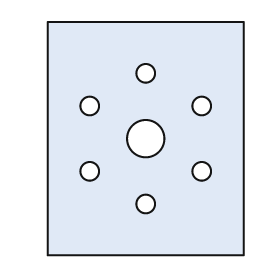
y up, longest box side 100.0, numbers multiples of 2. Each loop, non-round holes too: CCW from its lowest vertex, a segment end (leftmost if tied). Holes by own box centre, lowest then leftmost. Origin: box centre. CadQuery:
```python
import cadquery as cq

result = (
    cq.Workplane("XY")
    .moveTo(-42.0, -50.0)
    .lineTo(42.0, -50.0)
    .lineTo(42.0, 50.0)
    .lineTo(-42.0, 50.0)
    .close()
    .moveTo(0.0, -28.0)
    .circle(4.0)
    .moveTo(-24.0, -14.0)
    .circle(4.0)
    .moveTo(24.0, -14.0)
    .circle(4.0)
    .moveTo(0.0, 0.0)
    .circle(8.0)
    .moveTo(-24.0, 14.0)
    .circle(4.0)
    .moveTo(24.0, 14.0)
    .circle(4.0)
    .moveTo(0.0, 28.0)
    .circle(4.0)
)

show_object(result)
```